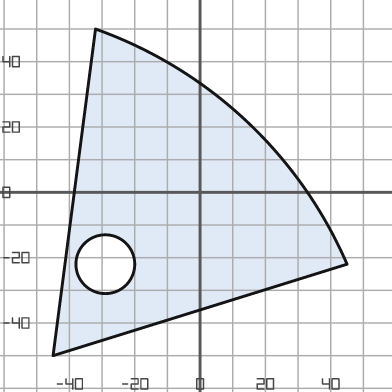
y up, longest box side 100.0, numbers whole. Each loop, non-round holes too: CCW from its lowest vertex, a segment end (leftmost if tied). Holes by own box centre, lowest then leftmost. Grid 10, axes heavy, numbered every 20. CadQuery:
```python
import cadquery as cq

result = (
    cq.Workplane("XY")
    .moveTo(-45.0, -50.0)
    .lineTo(45.0, -22.0)
    .threePointArc((14.0, 22.0), (-32.0, 50.0))
    .close()
    .moveTo(-29.0, -22.0)
    .circle(9.0)
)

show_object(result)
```